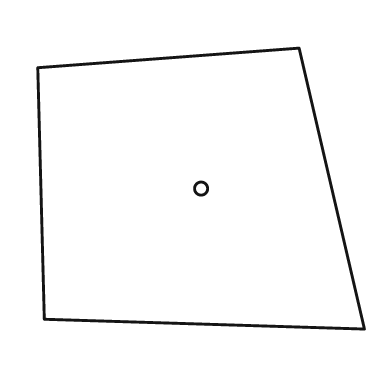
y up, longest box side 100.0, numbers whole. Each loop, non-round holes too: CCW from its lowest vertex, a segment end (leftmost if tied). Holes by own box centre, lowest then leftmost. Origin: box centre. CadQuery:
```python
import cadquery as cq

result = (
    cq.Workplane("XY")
    .moveTo(50.0, -43.0)
    .lineTo(30.0, 43.0)
    .lineTo(-50.0, 37.0)
    .lineTo(-48.0, -40.0)
    .close()
    .moveTo(0.0, 0.0)
    .circle(2.0)
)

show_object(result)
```